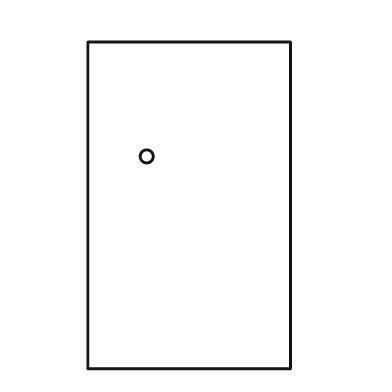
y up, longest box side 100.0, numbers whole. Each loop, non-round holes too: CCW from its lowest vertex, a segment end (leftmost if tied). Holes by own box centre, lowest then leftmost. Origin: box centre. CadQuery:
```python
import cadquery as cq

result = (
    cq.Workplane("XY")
    .moveTo(-31.0, -50.0)
    .lineTo(31.0, -50.0)
    .lineTo(31.0, 50.0)
    .lineTo(-31.0, 50.0)
    .close()
    .moveTo(-13.0, 15.0)
    .circle(2.0)
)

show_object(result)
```